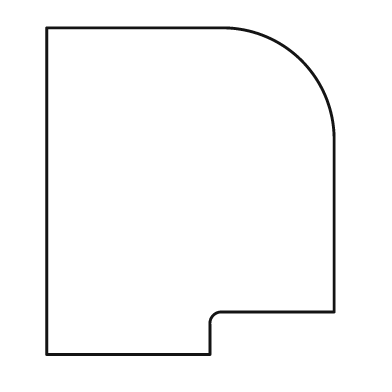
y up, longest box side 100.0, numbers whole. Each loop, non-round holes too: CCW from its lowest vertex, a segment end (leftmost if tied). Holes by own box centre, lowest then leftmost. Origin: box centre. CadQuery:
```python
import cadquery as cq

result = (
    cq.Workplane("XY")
    .moveTo(-44.0, -50.0)
    .lineTo(6.0, -50.0)
    .lineTo(6.0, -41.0)
    .threePointArc((7.0, -38.0), (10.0, -37.0))
    .lineTo(44.0, -37.0)
    .lineTo(44.0, 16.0)
    .threePointArc((34.0, 40.0), (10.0, 50.0))
    .lineTo(-44.0, 50.0)
    .close()
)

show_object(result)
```